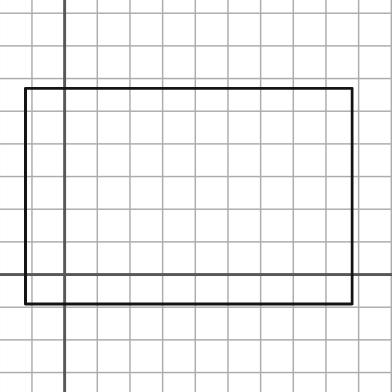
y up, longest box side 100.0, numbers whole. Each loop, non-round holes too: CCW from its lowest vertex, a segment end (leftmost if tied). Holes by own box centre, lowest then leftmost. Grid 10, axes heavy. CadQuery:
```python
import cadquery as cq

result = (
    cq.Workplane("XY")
    .moveTo(-12.0, -9.0)
    .lineTo(88.0, -9.0)
    .lineTo(88.0, 57.0)
    .lineTo(-12.0, 57.0)
    .close()
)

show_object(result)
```